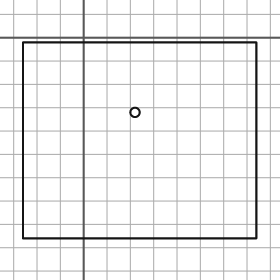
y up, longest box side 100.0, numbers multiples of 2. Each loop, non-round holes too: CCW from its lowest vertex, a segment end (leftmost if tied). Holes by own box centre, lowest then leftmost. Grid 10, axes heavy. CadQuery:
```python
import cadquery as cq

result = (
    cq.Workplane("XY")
    .moveTo(-26.0, -86.0)
    .lineTo(74.0, -86.0)
    .lineTo(74.0, -2.0)
    .lineTo(-26.0, -2.0)
    .close()
    .moveTo(22.0, -32.0)
    .circle(2.0)
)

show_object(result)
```